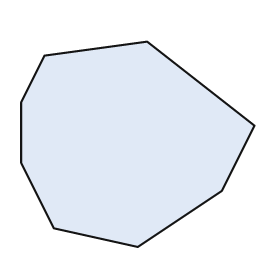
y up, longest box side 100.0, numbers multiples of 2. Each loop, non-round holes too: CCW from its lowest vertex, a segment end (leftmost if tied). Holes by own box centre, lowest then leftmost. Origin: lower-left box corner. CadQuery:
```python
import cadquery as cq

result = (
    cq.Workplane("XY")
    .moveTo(50.0, 0.0)
    .lineTo(86.0, 24.0)
    .lineTo(100.0, 52.0)
    .lineTo(54.0, 88.0)
    .lineTo(10.0, 82.0)
    .lineTo(0.0, 62.0)
    .lineTo(0.0, 36.0)
    .lineTo(14.0, 8.0)
    .close()
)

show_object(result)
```